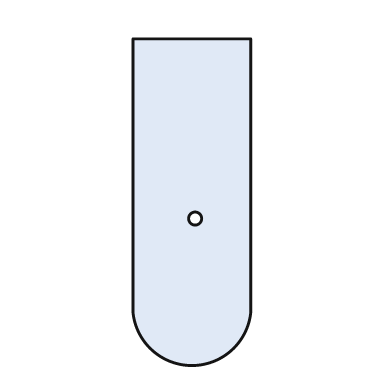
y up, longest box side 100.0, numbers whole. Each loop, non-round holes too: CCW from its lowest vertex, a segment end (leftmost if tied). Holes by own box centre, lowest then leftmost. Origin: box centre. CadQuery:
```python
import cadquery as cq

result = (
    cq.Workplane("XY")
    .moveTo(-18.0, -34.0)
    .threePointArc((0.0, -50.0), (18.0, -34.0))
    .lineTo(18.0, 50.0)
    .lineTo(-18.0, 50.0)
    .close()
    .moveTo(1.0, -5.0)
    .circle(2.0)
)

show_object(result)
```